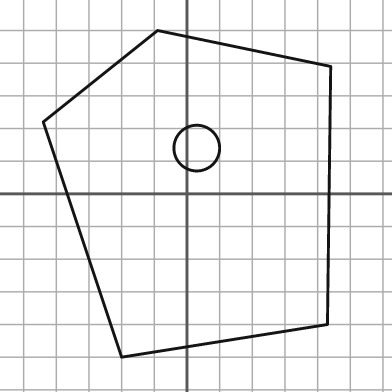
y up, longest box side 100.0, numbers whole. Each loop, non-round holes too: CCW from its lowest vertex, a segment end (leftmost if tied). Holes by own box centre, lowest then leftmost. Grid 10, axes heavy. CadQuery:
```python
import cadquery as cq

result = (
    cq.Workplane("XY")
    .moveTo(-20.0, -50.0)
    .lineTo(43.0, -40.0)
    .lineTo(44.0, 39.0)
    .lineTo(-9.0, 50.0)
    .lineTo(-44.0, 22.0)
    .close()
    .moveTo(3.0, 14.0)
    .circle(7.0)
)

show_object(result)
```